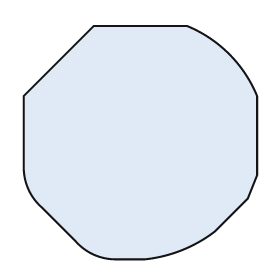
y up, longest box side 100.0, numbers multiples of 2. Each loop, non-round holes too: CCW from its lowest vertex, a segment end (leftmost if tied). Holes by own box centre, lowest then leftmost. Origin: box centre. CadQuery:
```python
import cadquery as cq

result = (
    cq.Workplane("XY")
    .moveTo(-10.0, -50.0)
    .lineTo(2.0, -50.0)
    .threePointArc((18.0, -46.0), (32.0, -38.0))
    .lineTo(46.0, -24.0)
    .lineTo(50.0, -14.0)
    .lineTo(50.0, 20.0)
    .threePointArc((38.0, 38.0), (20.0, 50.0))
    .lineTo(-20.0, 50.0)
    .lineTo(-50.0, 20.0)
    .lineTo(-50.0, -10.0)
    .threePointArc((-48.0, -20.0), (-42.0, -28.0))
    .lineTo(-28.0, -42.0)
    .threePointArc((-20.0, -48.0), (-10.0, -50.0))
    .close()
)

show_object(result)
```